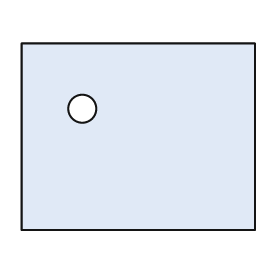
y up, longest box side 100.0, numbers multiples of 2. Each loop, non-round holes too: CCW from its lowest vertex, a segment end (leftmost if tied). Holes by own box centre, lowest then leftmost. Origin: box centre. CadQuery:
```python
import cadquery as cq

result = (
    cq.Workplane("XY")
    .moveTo(-50.0, -40.0)
    .lineTo(50.0, -40.0)
    .lineTo(50.0, 40.0)
    .lineTo(-50.0, 40.0)
    .close()
    .moveTo(-24.0, 12.0)
    .circle(6.0)
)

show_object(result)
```